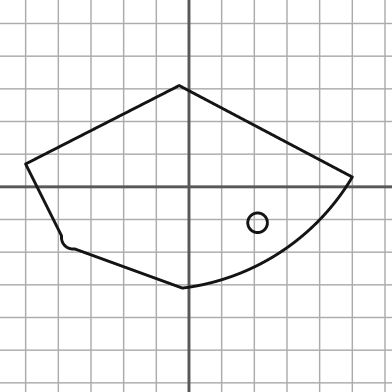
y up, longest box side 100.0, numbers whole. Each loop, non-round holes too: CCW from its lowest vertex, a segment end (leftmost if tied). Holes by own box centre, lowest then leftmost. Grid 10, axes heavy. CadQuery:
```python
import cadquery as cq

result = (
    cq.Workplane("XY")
    .moveTo(-2.0, -31.0)
    .threePointArc((28.0, -20.0), (50.0, 3.0))
    .lineTo(-3.0, 31.0)
    .lineTo(-50.0, 7.0)
    .lineTo(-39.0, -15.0)
    .threePointArc((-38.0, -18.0), (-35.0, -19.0))
    .close()
    .moveTo(21.0, -11.0)
    .circle(3.0)
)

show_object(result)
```